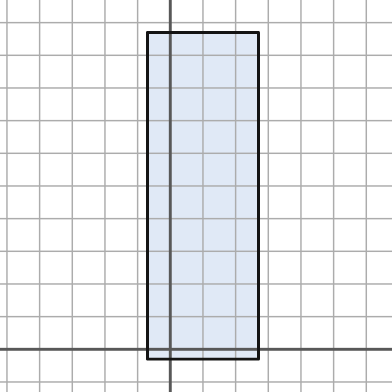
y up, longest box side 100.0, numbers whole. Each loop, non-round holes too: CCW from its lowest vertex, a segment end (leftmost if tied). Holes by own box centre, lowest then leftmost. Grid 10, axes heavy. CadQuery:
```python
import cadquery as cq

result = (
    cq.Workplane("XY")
    .moveTo(-7.0, -3.0)
    .lineTo(27.0, -3.0)
    .lineTo(27.0, 97.0)
    .lineTo(-7.0, 97.0)
    .close()
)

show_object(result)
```